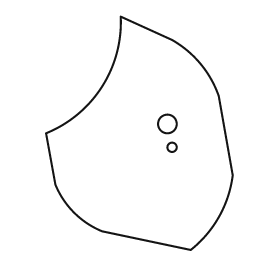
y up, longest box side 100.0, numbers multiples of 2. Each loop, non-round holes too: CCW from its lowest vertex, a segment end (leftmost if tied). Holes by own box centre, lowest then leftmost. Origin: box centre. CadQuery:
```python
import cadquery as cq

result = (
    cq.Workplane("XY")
    .moveTo(22.0, -50.0)
    .threePointArc((34.0, -36.0), (40.0, -18.0))
    .lineTo(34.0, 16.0)
    .threePointArc((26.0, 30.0), (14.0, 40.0))
    .lineTo(-8.0, 50.0)
    .threePointArc((-16.0, 20.0), (-40.0, 0.0))
    .lineTo(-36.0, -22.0)
    .threePointArc((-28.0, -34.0), (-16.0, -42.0))
    .close()
    .moveTo(14.0, -6.0)
    .circle(2.0)
    .moveTo(12.0, 4.0)
    .circle(4.0)
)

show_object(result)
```